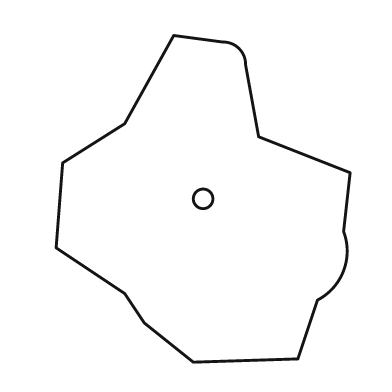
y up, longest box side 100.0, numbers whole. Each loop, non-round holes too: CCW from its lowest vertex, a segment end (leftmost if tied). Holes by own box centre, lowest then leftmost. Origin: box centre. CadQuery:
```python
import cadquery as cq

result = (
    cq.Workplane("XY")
    .moveTo(-3.0, -50.0)
    .lineTo(29.0, -49.0)
    .lineTo(35.0, -31.0)
    .threePointArc((43.0, -22.0), (43.0, -10.0))
    .lineTo(45.0, 8.0)
    .lineTo(17.0, 19.0)
    .lineTo(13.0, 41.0)
    .threePointArc((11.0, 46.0), (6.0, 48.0))
    .lineTo(-9.0, 50.0)
    .lineTo(-24.0, 23.0)
    .lineTo(-43.0, 11.0)
    .lineTo(-45.0, -15.0)
    .lineTo(-24.0, -29.0)
    .lineTo(-18.0, -38.0)
    .close()
    .moveTo(0.0, 0.0)
    .circle(3.0)
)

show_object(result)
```